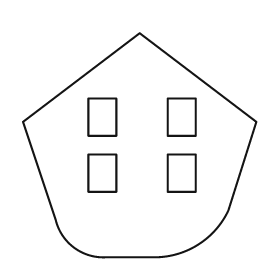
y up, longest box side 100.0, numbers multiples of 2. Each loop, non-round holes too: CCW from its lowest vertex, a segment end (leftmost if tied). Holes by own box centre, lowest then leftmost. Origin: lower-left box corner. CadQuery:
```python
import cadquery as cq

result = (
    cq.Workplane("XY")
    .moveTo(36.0, 0.0)
    .lineTo(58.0, 0.0)
    .threePointArc((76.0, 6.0), (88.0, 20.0))
    .lineTo(100.0, 58.0)
    .lineTo(50.0, 96.0)
    .lineTo(0.0, 58.0)
    .lineTo(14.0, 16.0)
    .threePointArc((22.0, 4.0), (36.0, 0.0))
    .close()
    .moveTo(28.0, 28.0)
    .lineTo(40.0, 28.0)
    .lineTo(40.0, 44.0)
    .lineTo(28.0, 44.0)
    .close()
    .moveTo(62.0, 28.0)
    .lineTo(74.0, 28.0)
    .lineTo(74.0, 44.0)
    .lineTo(62.0, 44.0)
    .close()
    .moveTo(28.0, 52.0)
    .lineTo(40.0, 52.0)
    .lineTo(40.0, 68.0)
    .lineTo(28.0, 68.0)
    .close()
    .moveTo(62.0, 52.0)
    .lineTo(74.0, 52.0)
    .lineTo(74.0, 68.0)
    .lineTo(62.0, 68.0)
    .close()
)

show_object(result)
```